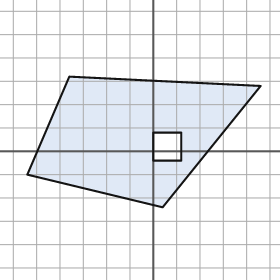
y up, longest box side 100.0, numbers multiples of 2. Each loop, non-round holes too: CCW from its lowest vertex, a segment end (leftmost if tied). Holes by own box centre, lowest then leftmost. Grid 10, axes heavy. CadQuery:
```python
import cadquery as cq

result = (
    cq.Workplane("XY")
    .moveTo(4.0, -24.0)
    .lineTo(46.0, 28.0)
    .lineTo(-36.0, 32.0)
    .lineTo(-54.0, -10.0)
    .close()
    .moveTo(0.0, -4.0)
    .lineTo(12.0, -4.0)
    .lineTo(12.0, 8.0)
    .lineTo(0.0, 8.0)
    .close()
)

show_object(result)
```